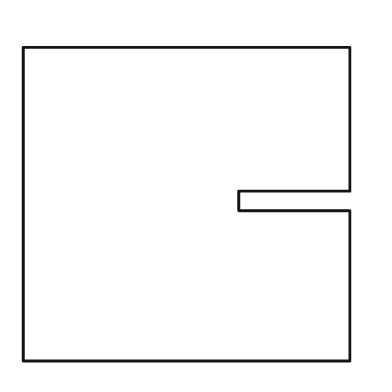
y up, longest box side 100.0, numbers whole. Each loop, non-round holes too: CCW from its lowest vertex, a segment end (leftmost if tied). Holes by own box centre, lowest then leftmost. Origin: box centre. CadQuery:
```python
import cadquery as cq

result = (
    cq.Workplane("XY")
    .moveTo(-50.0, -48.0)
    .lineTo(50.0, -48.0)
    .lineTo(50.0, -2.0)
    .lineTo(16.0, -2.0)
    .lineTo(16.0, 4.0)
    .lineTo(50.0, 4.0)
    .lineTo(50.0, 48.0)
    .lineTo(-50.0, 48.0)
    .close()
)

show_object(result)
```